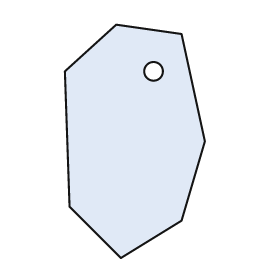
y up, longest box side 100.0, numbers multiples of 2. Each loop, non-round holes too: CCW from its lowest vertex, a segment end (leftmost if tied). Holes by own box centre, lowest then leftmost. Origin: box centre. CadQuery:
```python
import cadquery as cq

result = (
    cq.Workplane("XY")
    .moveTo(-6.0, -50.0)
    .lineTo(20.0, -34.0)
    .lineTo(30.0, 0.0)
    .lineTo(20.0, 46.0)
    .lineTo(-8.0, 50.0)
    .lineTo(-30.0, 30.0)
    .lineTo(-28.0, -28.0)
    .close()
    .moveTo(8.0, 30.0)
    .circle(4.0)
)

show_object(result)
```